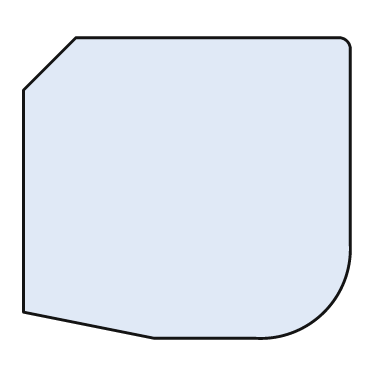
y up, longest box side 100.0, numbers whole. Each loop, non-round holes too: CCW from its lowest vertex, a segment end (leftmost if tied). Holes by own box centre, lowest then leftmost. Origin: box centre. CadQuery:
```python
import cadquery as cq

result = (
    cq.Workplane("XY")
    .moveTo(-10.0, -46.0)
    .lineTo(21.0, -46.0)
    .threePointArc((42.0, -38.0), (50.0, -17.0))
    .lineTo(50.0, 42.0)
    .threePointArc((49.0, 45.0), (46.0, 46.0))
    .lineTo(-34.0, 46.0)
    .lineTo(-50.0, 30.0)
    .lineTo(-50.0, -38.0)
    .close()
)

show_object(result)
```